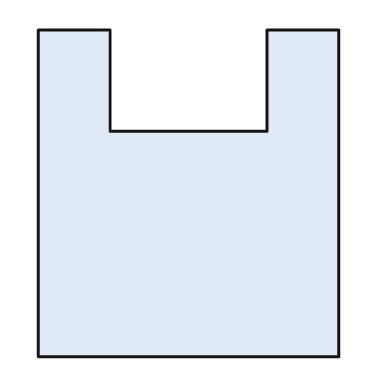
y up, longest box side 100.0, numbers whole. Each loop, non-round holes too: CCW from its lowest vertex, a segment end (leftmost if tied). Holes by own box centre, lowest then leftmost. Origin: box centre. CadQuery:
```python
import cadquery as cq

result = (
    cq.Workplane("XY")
    .moveTo(-46.0, -50.0)
    .lineTo(46.0, -50.0)
    .lineTo(46.0, 50.0)
    .lineTo(24.0, 50.0)
    .lineTo(24.0, 19.0)
    .lineTo(-24.0, 19.0)
    .lineTo(-24.0, 50.0)
    .lineTo(-46.0, 50.0)
    .close()
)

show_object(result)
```